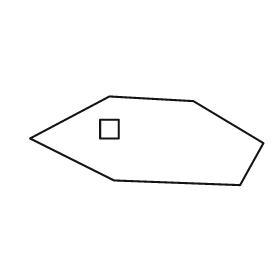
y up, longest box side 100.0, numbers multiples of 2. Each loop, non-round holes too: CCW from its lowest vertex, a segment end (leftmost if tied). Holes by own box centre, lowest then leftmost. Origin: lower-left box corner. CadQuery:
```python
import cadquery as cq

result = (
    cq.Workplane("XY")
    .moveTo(90.0, 0.0)
    .lineTo(100.0, 18.0)
    .lineTo(70.0, 36.0)
    .lineTo(34.0, 38.0)
    .lineTo(0.0, 20.0)
    .lineTo(36.0, 2.0)
    .close()
    .moveTo(30.0, 20.0)
    .lineTo(38.0, 20.0)
    .lineTo(38.0, 28.0)
    .lineTo(30.0, 28.0)
    .close()
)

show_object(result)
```